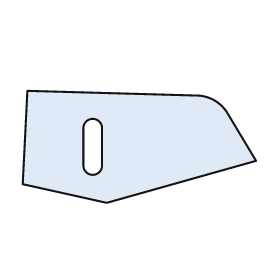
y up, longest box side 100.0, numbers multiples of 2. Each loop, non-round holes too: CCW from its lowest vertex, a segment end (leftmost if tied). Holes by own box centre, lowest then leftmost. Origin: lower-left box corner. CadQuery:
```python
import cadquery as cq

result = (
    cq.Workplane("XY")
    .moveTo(36.0, 0.0)
    .lineTo(100.0, 18.0)
    .lineTo(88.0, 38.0)
    .threePointArc((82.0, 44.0), (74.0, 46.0))
    .lineTo(2.0, 48.0)
    .lineTo(0.0, 8.0)
    .close()
    .moveTo(26.0, 16.0)
    .threePointArc((30.0, 12.0), (34.0, 16.0))
    .lineTo(34.0, 32.0)
    .threePointArc((30.0, 36.0), (26.0, 32.0))
    .close()
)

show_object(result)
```